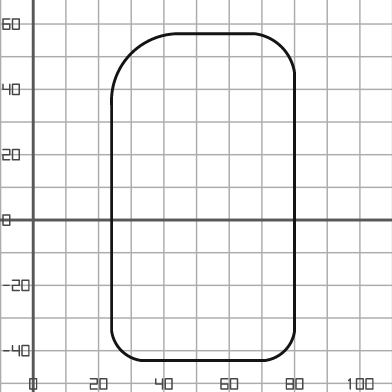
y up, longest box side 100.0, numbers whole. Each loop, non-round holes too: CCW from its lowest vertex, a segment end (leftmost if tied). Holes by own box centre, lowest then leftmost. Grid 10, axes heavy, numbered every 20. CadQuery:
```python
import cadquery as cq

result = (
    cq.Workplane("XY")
    .moveTo(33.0, -43.0)
    .lineTo(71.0, -43.0)
    .threePointArc((77.0, -40.0), (80.0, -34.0))
    .lineTo(80.0, 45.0)
    .threePointArc((76.0, 53.0), (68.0, 57.0))
    .lineTo(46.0, 57.0)
    .threePointArc((30.0, 51.0), (24.0, 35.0))
    .lineTo(24.0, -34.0)
    .threePointArc((27.0, -40.0), (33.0, -43.0))
    .close()
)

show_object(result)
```